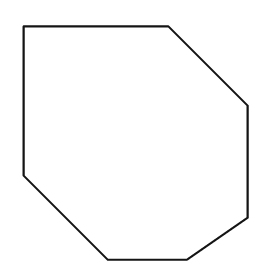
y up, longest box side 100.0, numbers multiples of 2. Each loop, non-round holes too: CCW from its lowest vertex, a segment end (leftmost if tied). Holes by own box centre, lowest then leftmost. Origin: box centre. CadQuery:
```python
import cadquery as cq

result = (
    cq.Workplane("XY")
    .moveTo(-12.0, -50.0)
    .lineTo(22.0, -50.0)
    .lineTo(48.0, -32.0)
    .lineTo(48.0, 16.0)
    .lineTo(14.0, 50.0)
    .lineTo(-48.0, 50.0)
    .lineTo(-48.0, -14.0)
    .close()
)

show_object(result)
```